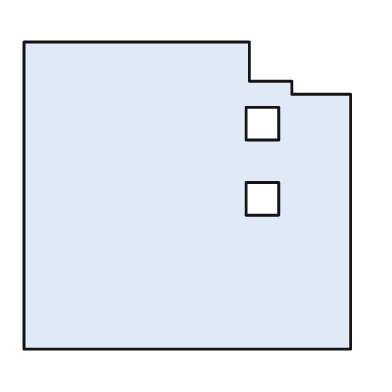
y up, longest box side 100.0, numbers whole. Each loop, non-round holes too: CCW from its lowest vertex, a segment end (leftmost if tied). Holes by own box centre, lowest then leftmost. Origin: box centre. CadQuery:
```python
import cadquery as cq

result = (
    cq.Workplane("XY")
    .moveTo(-50.0, -47.0)
    .lineTo(50.0, -47.0)
    .lineTo(50.0, 31.0)
    .lineTo(32.0, 31.0)
    .lineTo(32.0, 35.0)
    .lineTo(19.0, 35.0)
    .lineTo(19.0, 47.0)
    .lineTo(-50.0, 47.0)
    .close()
    .moveTo(18.0, -6.0)
    .lineTo(28.0, -6.0)
    .lineTo(28.0, 4.0)
    .lineTo(18.0, 4.0)
    .close()
    .moveTo(18.0, 17.0)
    .lineTo(28.0, 17.0)
    .lineTo(28.0, 27.0)
    .lineTo(18.0, 27.0)
    .close()
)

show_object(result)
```